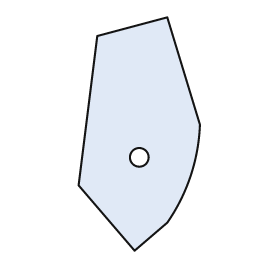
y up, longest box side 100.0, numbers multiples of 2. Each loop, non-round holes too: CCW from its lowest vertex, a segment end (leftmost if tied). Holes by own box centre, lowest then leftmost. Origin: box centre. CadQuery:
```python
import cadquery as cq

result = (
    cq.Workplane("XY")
    .moveTo(-2.0, -50.0)
    .lineTo(12.0, -38.0)
    .threePointArc((22.0, -18.0), (26.0, 4.0))
    .lineTo(12.0, 50.0)
    .lineTo(-18.0, 42.0)
    .lineTo(-26.0, -22.0)
    .close()
    .moveTo(0.0, -10.0)
    .circle(4.0)
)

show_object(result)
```